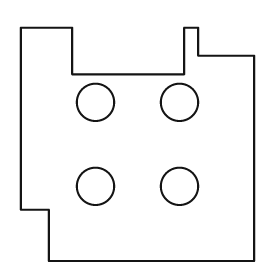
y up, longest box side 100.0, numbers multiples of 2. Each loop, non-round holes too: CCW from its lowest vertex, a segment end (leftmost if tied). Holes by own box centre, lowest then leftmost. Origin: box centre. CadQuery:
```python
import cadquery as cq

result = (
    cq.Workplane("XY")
    .moveTo(-38.0, -50.0)
    .lineTo(50.0, -50.0)
    .lineTo(50.0, 38.0)
    .lineTo(26.0, 38.0)
    .lineTo(26.0, 50.0)
    .lineTo(20.0, 50.0)
    .lineTo(20.0, 30.0)
    .lineTo(-28.0, 30.0)
    .lineTo(-28.0, 50.0)
    .lineTo(-50.0, 50.0)
    .lineTo(-50.0, -28.0)
    .lineTo(-38.0, -28.0)
    .close()
    .moveTo(-18.0, -18.0)
    .circle(8.0)
    .moveTo(18.0, -18.0)
    .circle(8.0)
    .moveTo(-18.0, 18.0)
    .circle(8.0)
    .moveTo(18.0, 18.0)
    .circle(8.0)
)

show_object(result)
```